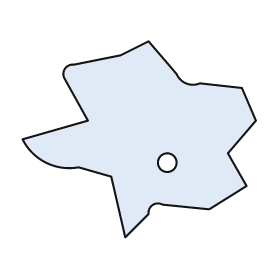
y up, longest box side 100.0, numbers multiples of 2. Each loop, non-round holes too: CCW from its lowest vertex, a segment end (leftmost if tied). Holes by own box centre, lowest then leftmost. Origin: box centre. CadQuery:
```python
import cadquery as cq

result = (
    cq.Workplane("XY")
    .moveTo(-6.0, -42.0)
    .lineTo(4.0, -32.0)
    .threePointArc((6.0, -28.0), (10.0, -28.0))
    .lineTo(30.0, -30.0)
    .lineTo(46.0, -20.0)
    .lineTo(38.0, -6.0)
    .lineTo(50.0, 8.0)
    .lineTo(44.0, 22.0)
    .lineTo(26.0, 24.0)
    .threePointArc((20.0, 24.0), (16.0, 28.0))
    .lineTo(4.0, 42.0)
    .lineTo(-8.0, 36.0)
    .lineTo(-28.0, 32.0)
    .threePointArc((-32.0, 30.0), (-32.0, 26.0))
    .lineTo(-22.0, 8.0)
    .lineTo(-50.0, 0.0)
    .threePointArc((-40.0, -10.0), (-26.0, -12.0))
    .lineTo(-12.0, -16.0)
    .close()
    .moveTo(12.0, -10.0)
    .circle(4.0)
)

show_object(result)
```